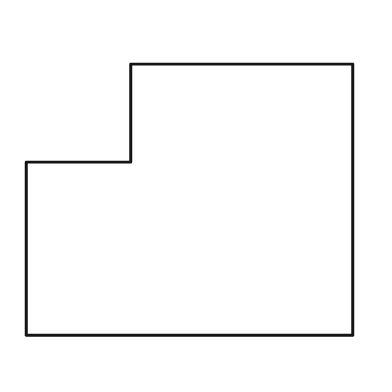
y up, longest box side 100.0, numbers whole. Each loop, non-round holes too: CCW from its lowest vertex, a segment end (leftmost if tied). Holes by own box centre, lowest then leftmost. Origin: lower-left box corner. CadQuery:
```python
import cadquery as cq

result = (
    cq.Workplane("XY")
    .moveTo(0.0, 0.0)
    .lineTo(100.0, 0.0)
    .lineTo(100.0, 83.0)
    .lineTo(32.0, 83.0)
    .lineTo(32.0, 53.0)
    .lineTo(0.0, 53.0)
    .close()
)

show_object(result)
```